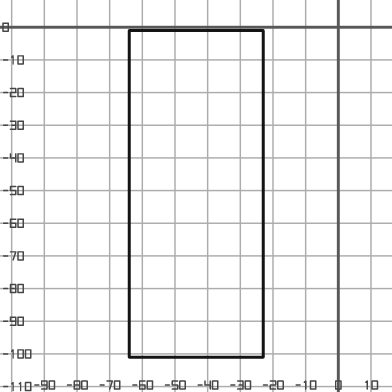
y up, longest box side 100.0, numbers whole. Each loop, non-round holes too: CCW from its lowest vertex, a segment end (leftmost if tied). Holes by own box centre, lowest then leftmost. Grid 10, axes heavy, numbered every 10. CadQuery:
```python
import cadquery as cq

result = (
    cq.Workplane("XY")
    .moveTo(-64.0, -101.0)
    .lineTo(-23.0, -101.0)
    .lineTo(-23.0, -1.0)
    .lineTo(-64.0, -1.0)
    .close()
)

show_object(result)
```